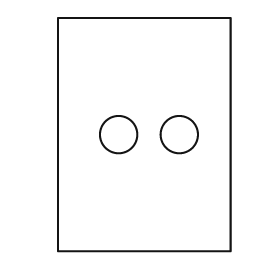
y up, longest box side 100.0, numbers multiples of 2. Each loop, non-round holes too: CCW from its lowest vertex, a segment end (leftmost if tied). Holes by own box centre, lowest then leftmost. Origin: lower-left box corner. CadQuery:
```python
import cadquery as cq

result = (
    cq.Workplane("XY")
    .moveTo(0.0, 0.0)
    .lineTo(74.0, 0.0)
    .lineTo(74.0, 100.0)
    .lineTo(0.0, 100.0)
    .close()
    .moveTo(26.0, 50.0)
    .circle(8.0)
    .moveTo(52.0, 50.0)
    .circle(8.0)
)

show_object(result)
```